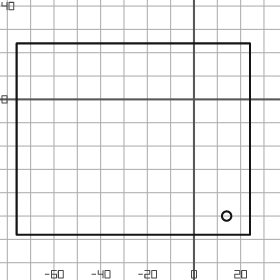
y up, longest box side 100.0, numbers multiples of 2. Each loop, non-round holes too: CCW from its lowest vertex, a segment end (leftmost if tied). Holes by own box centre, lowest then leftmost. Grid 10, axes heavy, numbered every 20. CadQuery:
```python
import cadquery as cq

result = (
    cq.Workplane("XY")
    .moveTo(-76.0, -58.0)
    .lineTo(24.0, -58.0)
    .lineTo(24.0, 24.0)
    .lineTo(-76.0, 24.0)
    .close()
    .moveTo(14.0, -50.0)
    .circle(2.0)
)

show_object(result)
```